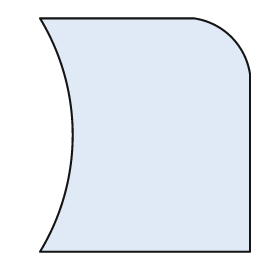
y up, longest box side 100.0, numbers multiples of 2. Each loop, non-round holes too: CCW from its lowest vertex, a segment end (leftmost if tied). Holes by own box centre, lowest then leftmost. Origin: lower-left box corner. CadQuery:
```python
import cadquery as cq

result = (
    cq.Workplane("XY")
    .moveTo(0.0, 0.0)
    .lineTo(90.0, 0.0)
    .lineTo(90.0, 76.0)
    .threePointArc((82.0, 92.0), (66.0, 100.0))
    .lineTo(0.0, 100.0)
    .threePointArc((14.0, 50.0), (0.0, 0.0))
    .close()
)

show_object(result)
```